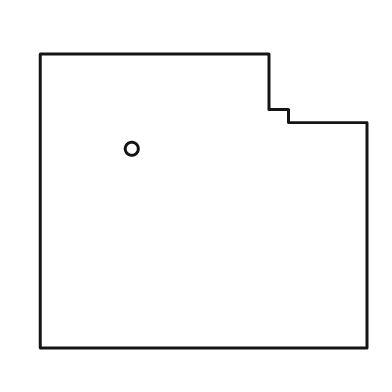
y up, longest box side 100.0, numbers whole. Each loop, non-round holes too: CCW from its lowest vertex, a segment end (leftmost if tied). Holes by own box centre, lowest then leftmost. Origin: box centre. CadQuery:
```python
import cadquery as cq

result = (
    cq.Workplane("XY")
    .moveTo(-50.0, -45.0)
    .lineTo(50.0, -45.0)
    .lineTo(50.0, 24.0)
    .lineTo(26.0, 24.0)
    .lineTo(26.0, 28.0)
    .lineTo(20.0, 28.0)
    .lineTo(20.0, 45.0)
    .lineTo(-50.0, 45.0)
    .close()
    .moveTo(-22.0, 16.0)
    .circle(2.0)
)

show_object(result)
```